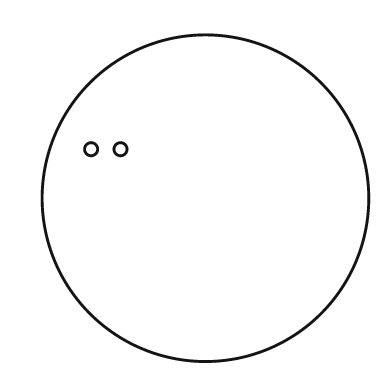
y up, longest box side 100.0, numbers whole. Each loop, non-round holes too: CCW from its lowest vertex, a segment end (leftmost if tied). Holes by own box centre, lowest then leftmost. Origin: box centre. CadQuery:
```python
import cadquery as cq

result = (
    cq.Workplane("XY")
    .moveTo(0.0, 0.0)
    .circle(50.0)
    .moveTo(-35.0, 15.0)
    .circle(2.0)
    .moveTo(-26.0, 15.0)
    .circle(2.0)
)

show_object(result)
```